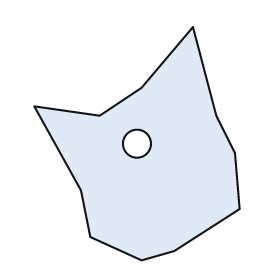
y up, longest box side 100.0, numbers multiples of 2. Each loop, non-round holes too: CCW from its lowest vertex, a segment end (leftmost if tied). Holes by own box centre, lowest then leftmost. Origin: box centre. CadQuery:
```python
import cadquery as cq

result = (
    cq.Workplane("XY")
    .moveTo(2.0, -50.0)
    .lineTo(16.0, -46.0)
    .lineTo(44.0, -28.0)
    .lineTo(42.0, -4.0)
    .lineTo(34.0, 12.0)
    .lineTo(24.0, 50.0)
    .lineTo(2.0, 24.0)
    .lineTo(-16.0, 12.0)
    .lineTo(-44.0, 16.0)
    .lineTo(-24.0, -20.0)
    .lineTo(-20.0, -40.0)
    .close()
    .moveTo(0.0, 0.0)
    .circle(6.0)
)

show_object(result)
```